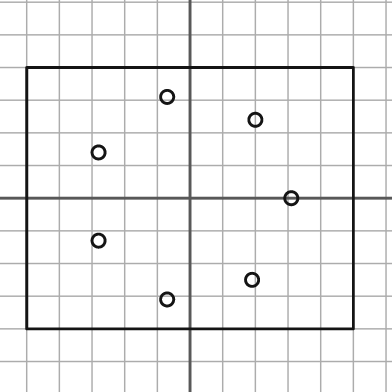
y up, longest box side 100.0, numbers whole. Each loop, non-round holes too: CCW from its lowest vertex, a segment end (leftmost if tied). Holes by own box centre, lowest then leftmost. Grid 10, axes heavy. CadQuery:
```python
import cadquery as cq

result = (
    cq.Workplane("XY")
    .moveTo(-50.0, -40.0)
    .lineTo(50.0, -40.0)
    .lineTo(50.0, 40.0)
    .lineTo(-50.0, 40.0)
    .close()
    .moveTo(-7.0, -31.0)
    .circle(2.0)
    .moveTo(19.0, -25.0)
    .circle(2.0)
    .moveTo(-28.0, -13.0)
    .circle(2.0)
    .moveTo(31.0, 0.0)
    .circle(2.0)
    .moveTo(-28.0, 14.0)
    .circle(2.0)
    .moveTo(20.0, 24.0)
    .circle(2.0)
    .moveTo(-7.0, 31.0)
    .circle(2.0)
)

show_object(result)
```